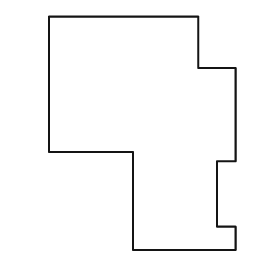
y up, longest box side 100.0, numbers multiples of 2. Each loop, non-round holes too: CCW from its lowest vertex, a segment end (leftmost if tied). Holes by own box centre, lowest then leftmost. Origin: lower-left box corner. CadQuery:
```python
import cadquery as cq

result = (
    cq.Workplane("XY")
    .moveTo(36.0, 0.0)
    .lineTo(80.0, 0.0)
    .lineTo(80.0, 10.0)
    .lineTo(72.0, 10.0)
    .lineTo(72.0, 38.0)
    .lineTo(80.0, 38.0)
    .lineTo(80.0, 78.0)
    .lineTo(64.0, 78.0)
    .lineTo(64.0, 100.0)
    .lineTo(0.0, 100.0)
    .lineTo(0.0, 42.0)
    .lineTo(36.0, 42.0)
    .close()
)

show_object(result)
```